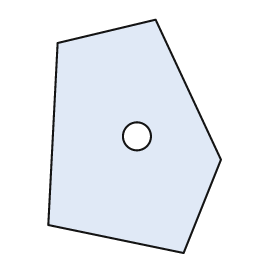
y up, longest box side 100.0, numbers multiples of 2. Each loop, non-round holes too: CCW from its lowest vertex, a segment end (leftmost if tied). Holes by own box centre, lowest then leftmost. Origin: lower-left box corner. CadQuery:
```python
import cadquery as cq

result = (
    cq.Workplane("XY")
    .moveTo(58.0, 0.0)
    .lineTo(74.0, 40.0)
    .lineTo(46.0, 100.0)
    .lineTo(4.0, 90.0)
    .lineTo(0.0, 12.0)
    .close()
    .moveTo(38.0, 50.0)
    .circle(6.0)
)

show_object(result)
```